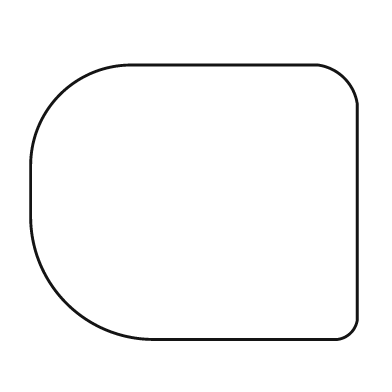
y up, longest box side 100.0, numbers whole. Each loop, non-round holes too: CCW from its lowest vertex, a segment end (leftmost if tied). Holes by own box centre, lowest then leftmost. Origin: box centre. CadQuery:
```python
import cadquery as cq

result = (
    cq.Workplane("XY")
    .moveTo(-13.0, -42.0)
    .lineTo(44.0, -42.0)
    .threePointArc((48.0, -40.0), (50.0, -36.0))
    .lineTo(50.0, 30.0)
    .threePointArc((46.0, 38.0), (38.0, 42.0))
    .lineTo(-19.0, 42.0)
    .threePointArc((-41.0, 33.0), (-50.0, 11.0))
    .lineTo(-50.0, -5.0)
    .threePointArc((-39.0, -31.0), (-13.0, -42.0))
    .close()
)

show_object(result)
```